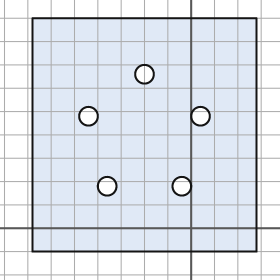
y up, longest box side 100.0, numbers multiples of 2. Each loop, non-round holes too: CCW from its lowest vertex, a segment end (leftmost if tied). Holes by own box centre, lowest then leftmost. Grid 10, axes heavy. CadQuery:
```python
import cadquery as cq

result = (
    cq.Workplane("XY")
    .moveTo(-68.0, -10.0)
    .lineTo(28.0, -10.0)
    .lineTo(28.0, 90.0)
    .lineTo(-68.0, 90.0)
    .close()
    .moveTo(-36.0, 18.0)
    .circle(4.0)
    .moveTo(-4.0, 18.0)
    .circle(4.0)
    .moveTo(-44.0, 48.0)
    .circle(4.0)
    .moveTo(4.0, 48.0)
    .circle(4.0)
    .moveTo(-20.0, 66.0)
    .circle(4.0)
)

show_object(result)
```